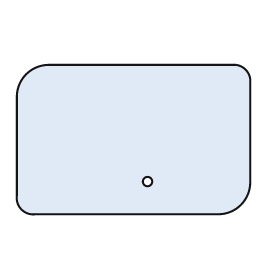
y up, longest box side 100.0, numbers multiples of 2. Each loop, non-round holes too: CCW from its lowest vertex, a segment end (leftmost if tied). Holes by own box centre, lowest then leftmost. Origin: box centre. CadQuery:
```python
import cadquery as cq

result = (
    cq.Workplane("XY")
    .moveTo(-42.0, -32.0)
    .lineTo(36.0, -32.0)
    .threePointArc((46.0, -28.0), (50.0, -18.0))
    .lineTo(50.0, 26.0)
    .threePointArc((48.0, 30.0), (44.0, 32.0))
    .lineTo(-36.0, 32.0)
    .threePointArc((-46.0, 28.0), (-50.0, 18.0))
    .lineTo(-50.0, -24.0)
    .threePointArc((-48.0, -30.0), (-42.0, -32.0))
    .close()
    .moveTo(6.0, -18.0)
    .circle(2.0)
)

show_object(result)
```